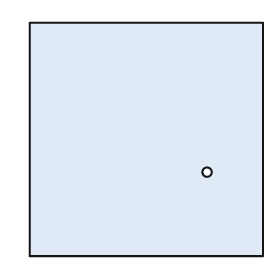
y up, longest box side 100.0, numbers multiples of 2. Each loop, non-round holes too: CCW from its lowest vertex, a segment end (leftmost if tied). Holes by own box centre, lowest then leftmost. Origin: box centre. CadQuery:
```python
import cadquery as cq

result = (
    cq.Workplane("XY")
    .moveTo(-50.0, -50.0)
    .lineTo(50.0, -50.0)
    .lineTo(50.0, 50.0)
    .lineTo(-50.0, 50.0)
    .close()
    .moveTo(26.0, -14.0)
    .circle(2.0)
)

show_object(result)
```